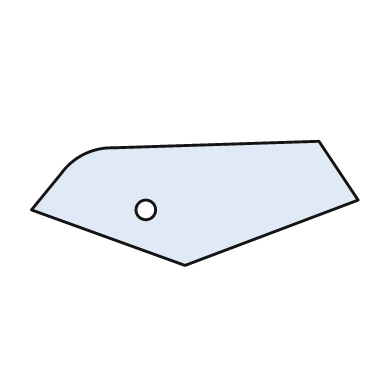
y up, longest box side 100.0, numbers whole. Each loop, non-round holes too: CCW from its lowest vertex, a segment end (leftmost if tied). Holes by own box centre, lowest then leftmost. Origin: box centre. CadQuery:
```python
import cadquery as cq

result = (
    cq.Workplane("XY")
    .moveTo(-3.0, -19.0)
    .lineTo(50.0, 1.0)
    .lineTo(38.0, 19.0)
    .lineTo(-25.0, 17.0)
    .threePointArc((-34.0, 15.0), (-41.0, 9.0))
    .lineTo(-50.0, -2.0)
    .close()
    .moveTo(-15.0, -2.0)
    .circle(3.0)
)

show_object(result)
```